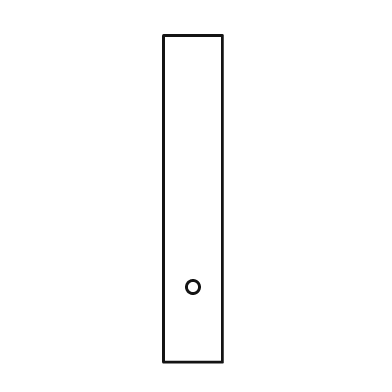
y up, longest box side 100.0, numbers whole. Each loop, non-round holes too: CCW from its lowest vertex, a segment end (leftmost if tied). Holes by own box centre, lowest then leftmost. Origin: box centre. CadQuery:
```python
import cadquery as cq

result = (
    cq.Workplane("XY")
    .moveTo(-9.0, -50.0)
    .lineTo(9.0, -50.0)
    .lineTo(9.0, 50.0)
    .lineTo(-9.0, 50.0)
    .close()
    .moveTo(0.0, -27.0)
    .circle(2.0)
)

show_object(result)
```